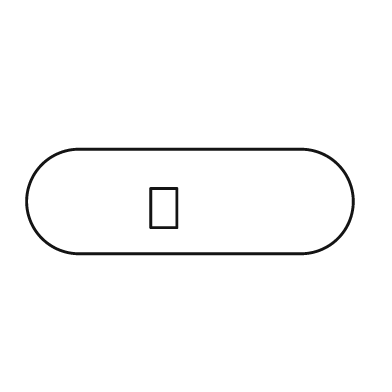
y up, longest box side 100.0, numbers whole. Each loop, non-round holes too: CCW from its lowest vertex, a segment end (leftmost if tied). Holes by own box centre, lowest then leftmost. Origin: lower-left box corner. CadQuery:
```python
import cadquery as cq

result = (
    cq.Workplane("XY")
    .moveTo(16.0, 0.0)
    .lineTo(84.0, 0.0)
    .threePointArc((100.0, 16.0), (84.0, 32.0))
    .lineTo(16.0, 32.0)
    .threePointArc((0.0, 16.0), (16.0, 0.0))
    .close()
    .moveTo(38.0, 8.0)
    .lineTo(46.0, 8.0)
    .lineTo(46.0, 20.0)
    .lineTo(38.0, 20.0)
    .close()
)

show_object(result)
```